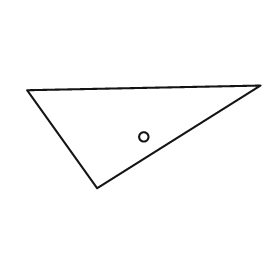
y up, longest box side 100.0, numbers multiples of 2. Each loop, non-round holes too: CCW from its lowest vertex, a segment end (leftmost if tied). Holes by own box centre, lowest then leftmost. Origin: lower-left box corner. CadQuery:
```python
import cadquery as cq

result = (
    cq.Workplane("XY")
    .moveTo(30.0, 0.0)
    .lineTo(100.0, 44.0)
    .lineTo(0.0, 42.0)
    .close()
    .moveTo(50.0, 22.0)
    .circle(2.0)
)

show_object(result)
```